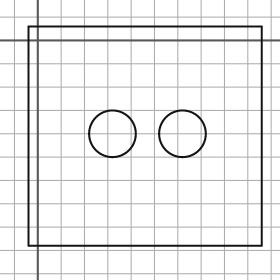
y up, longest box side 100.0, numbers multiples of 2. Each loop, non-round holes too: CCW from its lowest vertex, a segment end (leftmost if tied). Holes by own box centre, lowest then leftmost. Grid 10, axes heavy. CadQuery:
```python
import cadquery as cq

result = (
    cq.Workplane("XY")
    .moveTo(-4.0, -88.0)
    .lineTo(96.0, -88.0)
    .lineTo(96.0, 6.0)
    .lineTo(-4.0, 6.0)
    .close()
    .moveTo(32.0, -40.0)
    .circle(10.0)
    .moveTo(62.0, -40.0)
    .circle(10.0)
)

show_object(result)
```